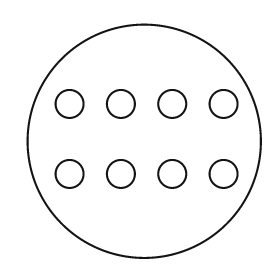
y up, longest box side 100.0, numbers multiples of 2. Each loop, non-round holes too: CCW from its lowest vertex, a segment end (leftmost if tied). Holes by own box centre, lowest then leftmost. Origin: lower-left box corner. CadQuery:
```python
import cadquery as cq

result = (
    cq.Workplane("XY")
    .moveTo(50.0, 50.0)
    .circle(50.0)
    .moveTo(18.0, 36.0)
    .circle(6.0)
    .moveTo(40.0, 36.0)
    .circle(6.0)
    .moveTo(62.0, 36.0)
    .circle(6.0)
    .moveTo(84.0, 36.0)
    .circle(6.0)
    .moveTo(18.0, 66.0)
    .circle(6.0)
    .moveTo(40.0, 66.0)
    .circle(6.0)
    .moveTo(62.0, 66.0)
    .circle(6.0)
    .moveTo(84.0, 66.0)
    .circle(6.0)
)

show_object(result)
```